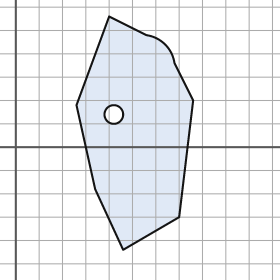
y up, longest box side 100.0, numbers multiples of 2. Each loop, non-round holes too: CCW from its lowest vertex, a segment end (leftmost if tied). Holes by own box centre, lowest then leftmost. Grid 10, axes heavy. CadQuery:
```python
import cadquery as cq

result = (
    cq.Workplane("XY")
    .moveTo(46.0, -44.0)
    .lineTo(70.0, -30.0)
    .lineTo(76.0, 20.0)
    .lineTo(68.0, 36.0)
    .threePointArc((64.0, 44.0), (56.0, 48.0))
    .lineTo(40.0, 56.0)
    .lineTo(26.0, 18.0)
    .lineTo(34.0, -18.0)
    .close()
    .moveTo(42.0, 14.0)
    .circle(4.0)
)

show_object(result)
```